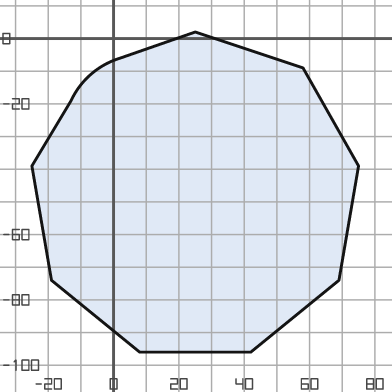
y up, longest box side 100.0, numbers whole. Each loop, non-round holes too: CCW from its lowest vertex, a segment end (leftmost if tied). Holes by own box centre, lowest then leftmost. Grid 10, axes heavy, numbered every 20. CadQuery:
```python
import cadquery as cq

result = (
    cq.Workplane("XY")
    .moveTo(8.0, -96.0)
    .lineTo(42.0, -96.0)
    .lineTo(69.0, -74.0)
    .lineTo(75.0, -39.0)
    .lineTo(58.0, -9.0)
    .lineTo(25.0, 2.0)
    .lineTo(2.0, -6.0)
    .threePointArc((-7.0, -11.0), (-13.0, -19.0))
    .lineTo(-25.0, -39.0)
    .lineTo(-19.0, -74.0)
    .close()
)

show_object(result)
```